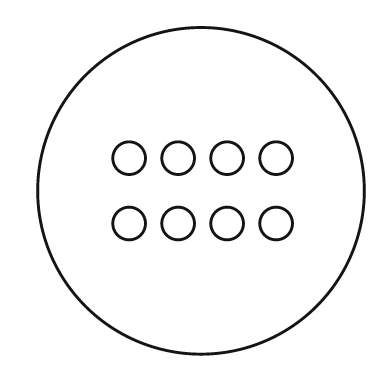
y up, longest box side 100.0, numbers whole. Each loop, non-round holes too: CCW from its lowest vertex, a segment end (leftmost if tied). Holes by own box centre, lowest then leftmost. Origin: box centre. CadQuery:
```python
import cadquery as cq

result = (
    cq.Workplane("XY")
    .moveTo(0.0, 0.0)
    .circle(50.0)
    .moveTo(-22.0, -10.0)
    .circle(5.0)
    .moveTo(-7.0, -10.0)
    .circle(5.0)
    .moveTo(8.0, -10.0)
    .circle(5.0)
    .moveTo(23.0, -10.0)
    .circle(5.0)
    .moveTo(-22.0, 10.0)
    .circle(5.0)
    .moveTo(-7.0, 10.0)
    .circle(5.0)
    .moveTo(8.0, 10.0)
    .circle(5.0)
    .moveTo(23.0, 10.0)
    .circle(5.0)
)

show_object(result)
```